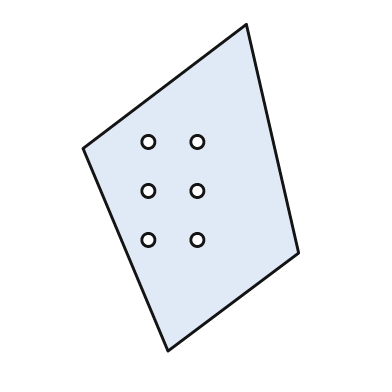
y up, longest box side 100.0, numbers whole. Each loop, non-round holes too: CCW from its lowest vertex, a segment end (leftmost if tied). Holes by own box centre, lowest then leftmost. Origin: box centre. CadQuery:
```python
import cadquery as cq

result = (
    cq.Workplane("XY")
    .moveTo(-7.0, -50.0)
    .lineTo(33.0, -20.0)
    .lineTo(17.0, 50.0)
    .lineTo(-33.0, 12.0)
    .close()
    .moveTo(-13.0, -16.0)
    .circle(2.0)
    .moveTo(2.0, -16.0)
    .circle(2.0)
    .moveTo(-13.0, -1.0)
    .circle(2.0)
    .moveTo(2.0, -1.0)
    .circle(2.0)
    .moveTo(-13.0, 14.0)
    .circle(2.0)
    .moveTo(2.0, 14.0)
    .circle(2.0)
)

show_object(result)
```